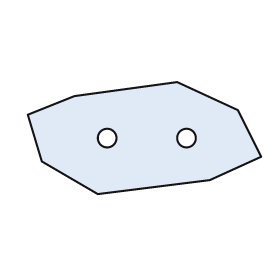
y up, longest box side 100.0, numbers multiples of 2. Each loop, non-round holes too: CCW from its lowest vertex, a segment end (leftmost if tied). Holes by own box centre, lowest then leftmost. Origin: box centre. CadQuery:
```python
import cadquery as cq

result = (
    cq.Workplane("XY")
    .moveTo(-20.0, -24.0)
    .lineTo(28.0, -18.0)
    .lineTo(50.0, -8.0)
    .lineTo(40.0, 12.0)
    .lineTo(14.0, 24.0)
    .lineTo(-30.0, 18.0)
    .lineTo(-50.0, 10.0)
    .lineTo(-44.0, -10.0)
    .close()
    .moveTo(-16.0, 0.0)
    .circle(4.0)
    .moveTo(18.0, 0.0)
    .circle(4.0)
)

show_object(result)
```